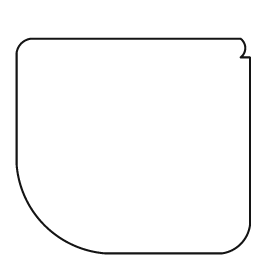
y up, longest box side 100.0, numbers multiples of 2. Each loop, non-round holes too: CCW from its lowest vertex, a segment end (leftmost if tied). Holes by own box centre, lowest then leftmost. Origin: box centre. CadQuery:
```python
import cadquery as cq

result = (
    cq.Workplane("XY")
    .moveTo(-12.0, -46.0)
    .lineTo(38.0, -46.0)
    .threePointArc((46.0, -42.0), (50.0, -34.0))
    .lineTo(50.0, 38.0)
    .lineTo(46.0, 38.0)
    .threePointArc((48.0, 42.0), (46.0, 46.0))
    .lineTo(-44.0, 46.0)
    .threePointArc((-48.0, 44.0), (-50.0, 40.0))
    .lineTo(-50.0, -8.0)
    .threePointArc((-38.0, -34.0), (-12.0, -46.0))
    .close()
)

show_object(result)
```